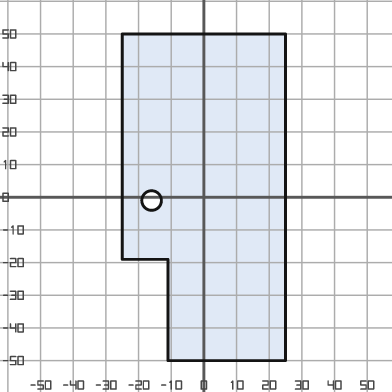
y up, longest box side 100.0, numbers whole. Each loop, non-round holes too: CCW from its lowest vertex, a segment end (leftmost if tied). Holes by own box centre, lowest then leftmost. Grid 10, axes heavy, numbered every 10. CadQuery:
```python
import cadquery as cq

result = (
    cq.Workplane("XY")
    .moveTo(-11.0, -50.0)
    .lineTo(25.0, -50.0)
    .lineTo(25.0, 50.0)
    .lineTo(-25.0, 50.0)
    .lineTo(-25.0, -19.0)
    .lineTo(-11.0, -19.0)
    .close()
    .moveTo(-16.0, -1.0)
    .circle(3.0)
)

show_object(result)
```